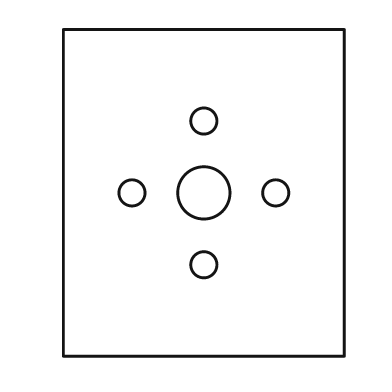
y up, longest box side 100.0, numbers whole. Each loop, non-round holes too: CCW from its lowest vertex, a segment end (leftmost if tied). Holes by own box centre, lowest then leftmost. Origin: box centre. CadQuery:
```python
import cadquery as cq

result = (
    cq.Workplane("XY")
    .moveTo(-43.0, -50.0)
    .lineTo(43.0, -50.0)
    .lineTo(43.0, 50.0)
    .lineTo(-43.0, 50.0)
    .close()
    .moveTo(0.0, -22.0)
    .circle(4.0)
    .moveTo(-22.0, 0.0)
    .circle(4.0)
    .moveTo(0.0, 0.0)
    .circle(8.0)
    .moveTo(22.0, 0.0)
    .circle(4.0)
    .moveTo(0.0, 22.0)
    .circle(4.0)
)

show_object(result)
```